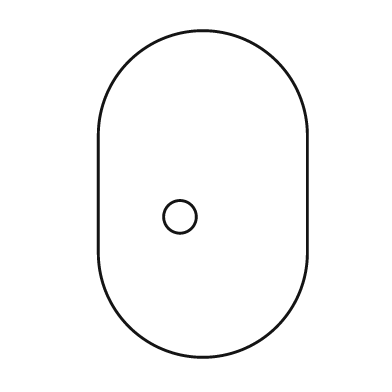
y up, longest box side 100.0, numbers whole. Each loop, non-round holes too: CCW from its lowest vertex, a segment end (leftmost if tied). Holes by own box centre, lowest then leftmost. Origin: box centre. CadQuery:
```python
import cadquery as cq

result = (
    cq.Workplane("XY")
    .moveTo(-32.0, -18.0)
    .threePointArc((0.0, -50.0), (32.0, -18.0))
    .lineTo(32.0, 18.0)
    .threePointArc((0.0, 50.0), (-32.0, 18.0))
    .close()
    .moveTo(-7.0, -7.0)
    .circle(5.0)
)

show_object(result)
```